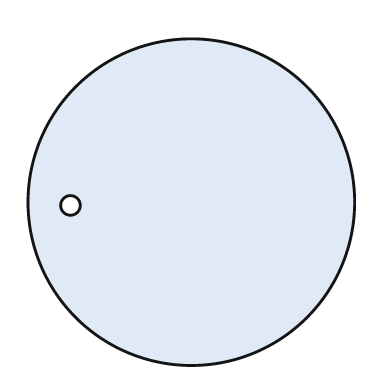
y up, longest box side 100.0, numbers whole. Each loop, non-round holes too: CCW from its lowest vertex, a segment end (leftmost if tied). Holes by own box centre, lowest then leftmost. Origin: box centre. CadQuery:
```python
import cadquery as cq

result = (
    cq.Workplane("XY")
    .moveTo(0.0, 0.0)
    .circle(50.0)
    .moveTo(-37.0, -1.0)
    .circle(3.0)
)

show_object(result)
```